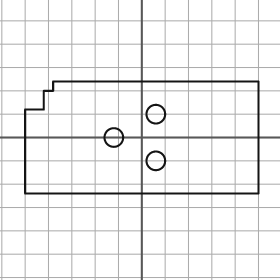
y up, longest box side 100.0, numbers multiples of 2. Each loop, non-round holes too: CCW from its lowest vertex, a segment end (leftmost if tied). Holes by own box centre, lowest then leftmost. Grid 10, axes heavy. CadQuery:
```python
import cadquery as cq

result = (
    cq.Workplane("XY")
    .moveTo(-50.0, -24.0)
    .lineTo(50.0, -24.0)
    .lineTo(50.0, 24.0)
    .lineTo(-38.0, 24.0)
    .lineTo(-38.0, 20.0)
    .lineTo(-42.0, 20.0)
    .lineTo(-42.0, 12.0)
    .lineTo(-50.0, 12.0)
    .close()
    .moveTo(6.0, -10.0)
    .circle(4.0)
    .moveTo(-12.0, 0.0)
    .circle(4.0)
    .moveTo(6.0, 10.0)
    .circle(4.0)
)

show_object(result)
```